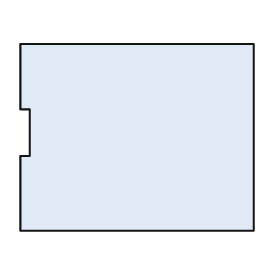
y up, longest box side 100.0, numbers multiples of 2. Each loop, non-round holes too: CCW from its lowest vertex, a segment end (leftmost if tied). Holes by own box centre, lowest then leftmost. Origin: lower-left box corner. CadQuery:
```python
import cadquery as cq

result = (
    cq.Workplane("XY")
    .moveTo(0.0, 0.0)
    .lineTo(100.0, 0.0)
    .lineTo(100.0, 80.0)
    .lineTo(0.0, 80.0)
    .lineTo(0.0, 52.0)
    .lineTo(4.0, 52.0)
    .lineTo(4.0, 32.0)
    .lineTo(0.0, 32.0)
    .close()
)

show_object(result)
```